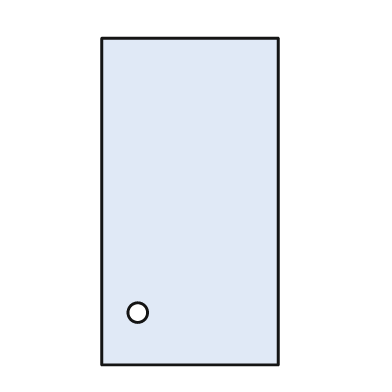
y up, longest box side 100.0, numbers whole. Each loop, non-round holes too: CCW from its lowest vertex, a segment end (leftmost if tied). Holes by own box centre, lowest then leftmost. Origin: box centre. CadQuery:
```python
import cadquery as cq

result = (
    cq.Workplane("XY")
    .moveTo(-27.0, -50.0)
    .lineTo(27.0, -50.0)
    .lineTo(27.0, 50.0)
    .lineTo(-27.0, 50.0)
    .close()
    .moveTo(-16.0, -34.0)
    .circle(3.0)
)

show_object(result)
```